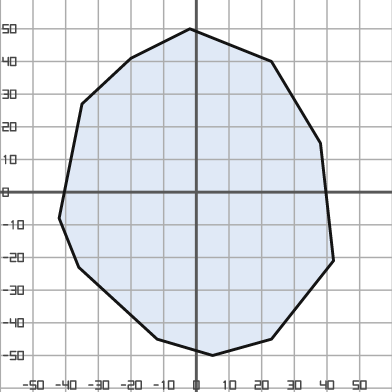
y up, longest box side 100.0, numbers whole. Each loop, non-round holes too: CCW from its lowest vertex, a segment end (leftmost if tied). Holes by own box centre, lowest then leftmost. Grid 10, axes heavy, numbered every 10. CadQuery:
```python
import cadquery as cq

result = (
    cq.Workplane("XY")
    .moveTo(5.0, -50.0)
    .lineTo(23.0, -45.0)
    .lineTo(42.0, -21.0)
    .lineTo(38.0, 15.0)
    .lineTo(23.0, 40.0)
    .lineTo(-2.0, 50.0)
    .lineTo(-20.0, 41.0)
    .lineTo(-35.0, 27.0)
    .lineTo(-42.0, -8.0)
    .lineTo(-36.0, -23.0)
    .lineTo(-12.0, -45.0)
    .close()
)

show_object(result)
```